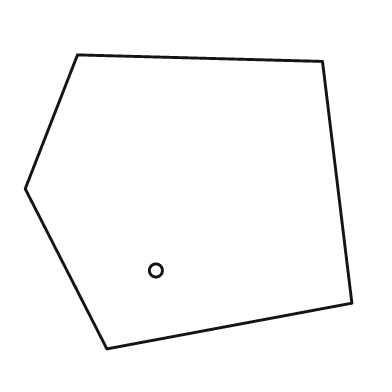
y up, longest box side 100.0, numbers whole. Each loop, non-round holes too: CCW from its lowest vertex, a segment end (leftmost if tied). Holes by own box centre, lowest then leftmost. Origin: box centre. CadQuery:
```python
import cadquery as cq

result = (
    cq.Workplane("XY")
    .moveTo(-25.0, -45.0)
    .lineTo(50.0, -31.0)
    .lineTo(41.0, 43.0)
    .lineTo(-34.0, 45.0)
    .lineTo(-50.0, 4.0)
    .close()
    .moveTo(-10.0, -21.0)
    .circle(2.0)
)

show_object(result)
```